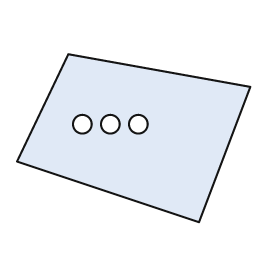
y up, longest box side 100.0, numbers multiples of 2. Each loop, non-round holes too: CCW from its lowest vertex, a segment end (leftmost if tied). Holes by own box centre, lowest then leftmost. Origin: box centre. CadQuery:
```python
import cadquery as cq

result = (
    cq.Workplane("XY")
    .moveTo(28.0, -36.0)
    .lineTo(50.0, 22.0)
    .lineTo(-28.0, 36.0)
    .lineTo(-50.0, -10.0)
    .close()
    .moveTo(-22.0, 6.0)
    .circle(4.0)
    .moveTo(-10.0, 6.0)
    .circle(4.0)
    .moveTo(2.0, 6.0)
    .circle(4.0)
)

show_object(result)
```